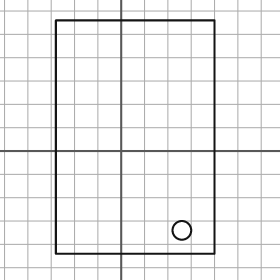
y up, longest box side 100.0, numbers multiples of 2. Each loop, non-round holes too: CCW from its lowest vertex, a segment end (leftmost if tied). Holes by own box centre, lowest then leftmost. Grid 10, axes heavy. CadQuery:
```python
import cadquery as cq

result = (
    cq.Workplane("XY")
    .moveTo(-28.0, -44.0)
    .lineTo(40.0, -44.0)
    .lineTo(40.0, 56.0)
    .lineTo(-28.0, 56.0)
    .close()
    .moveTo(26.0, -34.0)
    .circle(4.0)
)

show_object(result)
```